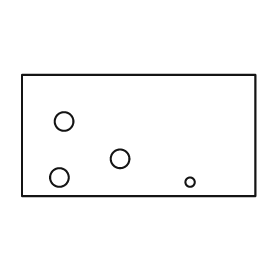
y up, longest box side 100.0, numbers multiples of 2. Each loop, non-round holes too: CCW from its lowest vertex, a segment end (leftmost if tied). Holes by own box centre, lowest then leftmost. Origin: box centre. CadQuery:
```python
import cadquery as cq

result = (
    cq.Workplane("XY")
    .moveTo(-50.0, -26.0)
    .lineTo(50.0, -26.0)
    .lineTo(50.0, 26.0)
    .lineTo(-50.0, 26.0)
    .close()
    .moveTo(22.0, -20.0)
    .circle(2.0)
    .moveTo(-34.0, -18.0)
    .circle(4.0)
    .moveTo(-8.0, -10.0)
    .circle(4.0)
    .moveTo(-32.0, 6.0)
    .circle(4.0)
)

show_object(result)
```